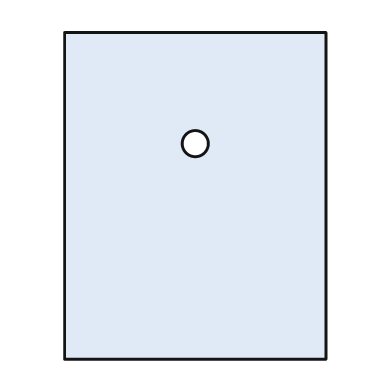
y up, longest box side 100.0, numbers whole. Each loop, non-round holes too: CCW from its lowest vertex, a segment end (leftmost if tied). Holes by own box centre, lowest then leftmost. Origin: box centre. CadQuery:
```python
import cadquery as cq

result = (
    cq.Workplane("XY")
    .moveTo(-40.0, -50.0)
    .lineTo(40.0, -50.0)
    .lineTo(40.0, 50.0)
    .lineTo(-40.0, 50.0)
    .close()
    .moveTo(0.0, 16.0)
    .circle(4.0)
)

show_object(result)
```